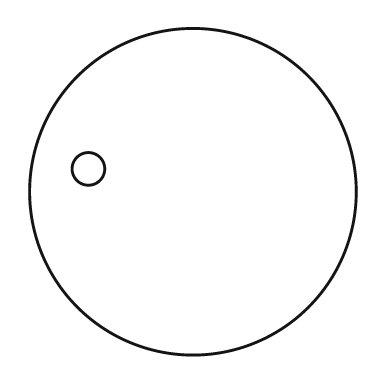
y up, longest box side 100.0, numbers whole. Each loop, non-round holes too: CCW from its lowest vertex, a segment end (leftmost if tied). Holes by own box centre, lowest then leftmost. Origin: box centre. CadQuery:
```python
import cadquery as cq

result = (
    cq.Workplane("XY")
    .moveTo(0.0, 0.0)
    .circle(50.0)
    .moveTo(-32.0, 7.0)
    .circle(5.0)
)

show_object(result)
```